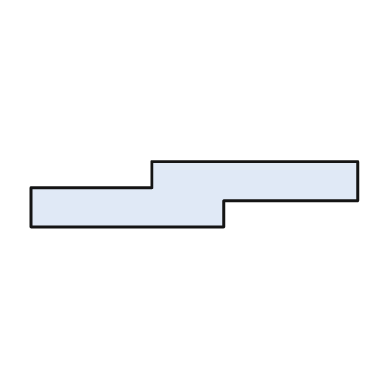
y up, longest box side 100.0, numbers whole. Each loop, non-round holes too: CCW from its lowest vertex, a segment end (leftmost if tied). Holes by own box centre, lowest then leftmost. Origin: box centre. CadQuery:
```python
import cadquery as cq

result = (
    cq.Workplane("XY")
    .moveTo(-50.0, -10.0)
    .lineTo(9.0, -10.0)
    .lineTo(9.0, -2.0)
    .lineTo(50.0, -2.0)
    .lineTo(50.0, 10.0)
    .lineTo(-13.0, 10.0)
    .lineTo(-13.0, 2.0)
    .lineTo(-50.0, 2.0)
    .close()
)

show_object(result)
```